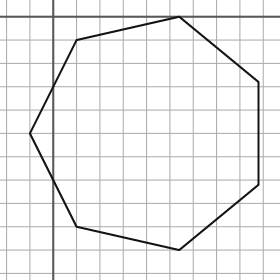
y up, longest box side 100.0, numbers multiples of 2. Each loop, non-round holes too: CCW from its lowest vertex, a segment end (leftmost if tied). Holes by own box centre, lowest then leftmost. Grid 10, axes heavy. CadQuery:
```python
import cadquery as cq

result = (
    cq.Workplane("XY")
    .moveTo(54.0, -100.0)
    .lineTo(88.0, -72.0)
    .lineTo(88.0, -28.0)
    .lineTo(54.0, 0.0)
    .lineTo(10.0, -10.0)
    .lineTo(-10.0, -50.0)
    .lineTo(10.0, -90.0)
    .close()
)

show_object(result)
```